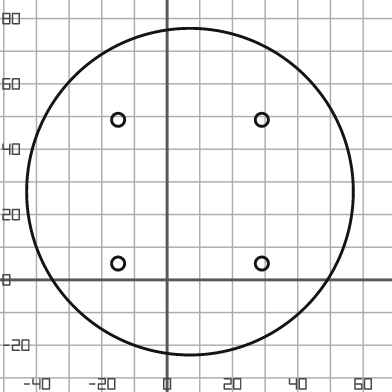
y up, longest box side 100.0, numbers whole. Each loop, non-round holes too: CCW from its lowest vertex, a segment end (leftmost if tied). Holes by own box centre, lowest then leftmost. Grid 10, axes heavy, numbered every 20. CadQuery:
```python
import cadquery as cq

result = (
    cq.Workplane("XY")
    .moveTo(7.0, 27.0)
    .circle(50.0)
    .moveTo(-15.0, 5.0)
    .circle(2.0)
    .moveTo(29.0, 5.0)
    .circle(2.0)
    .moveTo(-15.0, 49.0)
    .circle(2.0)
    .moveTo(29.0, 49.0)
    .circle(2.0)
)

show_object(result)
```